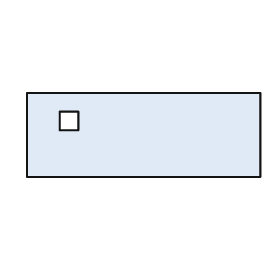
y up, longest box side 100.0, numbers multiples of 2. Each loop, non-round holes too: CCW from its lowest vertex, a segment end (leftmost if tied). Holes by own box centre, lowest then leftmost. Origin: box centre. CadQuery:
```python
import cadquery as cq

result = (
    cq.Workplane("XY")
    .moveTo(-50.0, -18.0)
    .lineTo(50.0, -18.0)
    .lineTo(50.0, 18.0)
    .lineTo(-50.0, 18.0)
    .close()
    .moveTo(-36.0, 2.0)
    .lineTo(-28.0, 2.0)
    .lineTo(-28.0, 10.0)
    .lineTo(-36.0, 10.0)
    .close()
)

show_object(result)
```